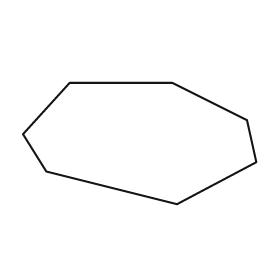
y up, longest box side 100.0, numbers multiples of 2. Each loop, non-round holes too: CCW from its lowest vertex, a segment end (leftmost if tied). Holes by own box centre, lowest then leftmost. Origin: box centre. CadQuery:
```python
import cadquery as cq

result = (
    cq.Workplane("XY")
    .moveTo(16.0, -26.0)
    .lineTo(50.0, -8.0)
    .lineTo(46.0, 10.0)
    .lineTo(14.0, 26.0)
    .lineTo(-30.0, 26.0)
    .lineTo(-50.0, 4.0)
    .lineTo(-40.0, -12.0)
    .close()
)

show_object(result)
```